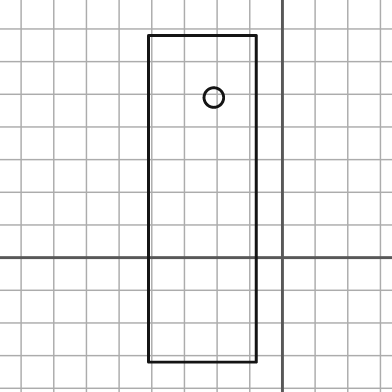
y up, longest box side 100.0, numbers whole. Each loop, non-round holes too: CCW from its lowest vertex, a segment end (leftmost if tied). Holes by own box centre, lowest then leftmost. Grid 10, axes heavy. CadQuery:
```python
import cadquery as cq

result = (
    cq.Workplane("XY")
    .moveTo(-41.0, -32.0)
    .lineTo(-8.0, -32.0)
    .lineTo(-8.0, 68.0)
    .lineTo(-41.0, 68.0)
    .close()
    .moveTo(-21.0, 49.0)
    .circle(3.0)
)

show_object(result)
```